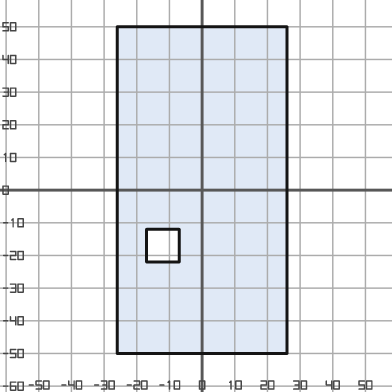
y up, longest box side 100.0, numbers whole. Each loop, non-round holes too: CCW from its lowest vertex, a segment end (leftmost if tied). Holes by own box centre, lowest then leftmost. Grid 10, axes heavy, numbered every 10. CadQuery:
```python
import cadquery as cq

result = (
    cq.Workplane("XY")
    .moveTo(-26.0, -50.0)
    .lineTo(26.0, -50.0)
    .lineTo(26.0, 50.0)
    .lineTo(-26.0, 50.0)
    .close()
    .moveTo(-17.0, -22.0)
    .lineTo(-7.0, -22.0)
    .lineTo(-7.0, -12.0)
    .lineTo(-17.0, -12.0)
    .close()
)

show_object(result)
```